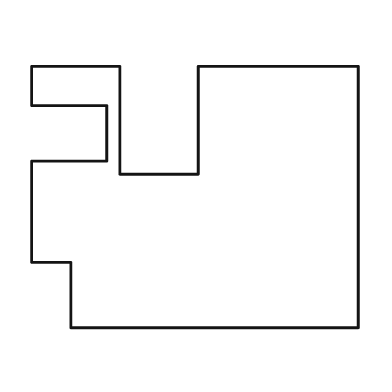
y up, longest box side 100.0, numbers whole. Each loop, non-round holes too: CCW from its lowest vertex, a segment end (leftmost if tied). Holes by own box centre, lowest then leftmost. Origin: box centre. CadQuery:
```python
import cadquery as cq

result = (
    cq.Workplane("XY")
    .moveTo(-38.0, -40.0)
    .lineTo(50.0, -40.0)
    .lineTo(50.0, 40.0)
    .lineTo(1.0, 40.0)
    .lineTo(1.0, 7.0)
    .lineTo(-23.0, 7.0)
    .lineTo(-23.0, 40.0)
    .lineTo(-50.0, 40.0)
    .lineTo(-50.0, 28.0)
    .lineTo(-27.0, 28.0)
    .lineTo(-27.0, 11.0)
    .lineTo(-50.0, 11.0)
    .lineTo(-50.0, -20.0)
    .lineTo(-38.0, -20.0)
    .close()
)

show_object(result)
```